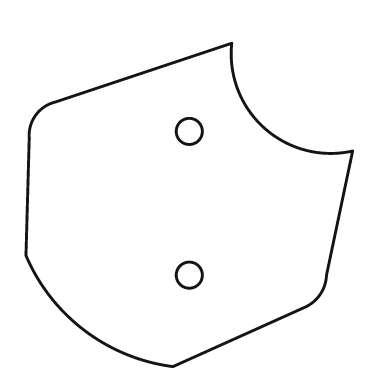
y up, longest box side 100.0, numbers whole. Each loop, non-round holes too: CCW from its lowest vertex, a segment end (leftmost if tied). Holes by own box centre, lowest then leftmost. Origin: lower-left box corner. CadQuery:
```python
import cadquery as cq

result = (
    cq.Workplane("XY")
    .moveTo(45.0, 0.0)
    .lineTo(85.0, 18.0)
    .threePointArc((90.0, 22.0), (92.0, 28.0))
    .lineTo(100.0, 66.0)
    .threePointArc((73.0, 73.0), (63.0, 99.0))
    .lineTo(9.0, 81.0)
    .threePointArc((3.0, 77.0), (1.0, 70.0))
    .lineTo(0.0, 34.0)
    .threePointArc((18.0, 11.0), (45.0, 0.0))
    .close()
    .moveTo(50.0, 28.0)
    .circle(4.0)
    .moveTo(50.0, 72.0)
    .circle(4.0)
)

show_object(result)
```